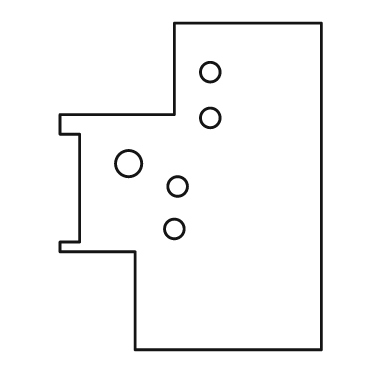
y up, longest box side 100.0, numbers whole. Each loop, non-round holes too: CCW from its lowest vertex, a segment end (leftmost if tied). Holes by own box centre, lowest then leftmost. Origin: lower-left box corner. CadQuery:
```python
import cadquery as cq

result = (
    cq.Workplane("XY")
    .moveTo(23.0, 0.0)
    .lineTo(80.0, 0.0)
    .lineTo(80.0, 100.0)
    .lineTo(35.0, 100.0)
    .lineTo(35.0, 72.0)
    .lineTo(0.0, 72.0)
    .lineTo(0.0, 66.0)
    .lineTo(6.0, 66.0)
    .lineTo(6.0, 33.0)
    .lineTo(0.0, 33.0)
    .lineTo(0.0, 30.0)
    .lineTo(23.0, 30.0)
    .close()
    .moveTo(35.0, 37.0)
    .circle(3.0)
    .moveTo(36.0, 50.0)
    .circle(3.0)
    .moveTo(21.0, 57.0)
    .circle(4.0)
    .moveTo(46.0, 71.0)
    .circle(3.0)
    .moveTo(46.0, 85.0)
    .circle(3.0)
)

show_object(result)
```